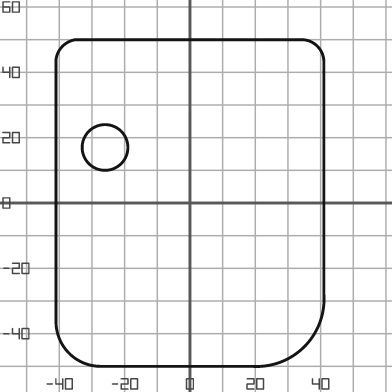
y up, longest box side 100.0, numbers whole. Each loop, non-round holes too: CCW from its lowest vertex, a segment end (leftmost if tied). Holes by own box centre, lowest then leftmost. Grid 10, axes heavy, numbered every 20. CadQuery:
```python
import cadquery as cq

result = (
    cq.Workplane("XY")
    .moveTo(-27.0, -50.0)
    .lineTo(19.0, -50.0)
    .threePointArc((35.0, -44.0), (41.0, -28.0))
    .lineTo(41.0, 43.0)
    .threePointArc((39.0, 48.0), (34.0, 50.0))
    .lineTo(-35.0, 50.0)
    .threePointArc((-39.0, 48.0), (-41.0, 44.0))
    .lineTo(-41.0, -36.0)
    .threePointArc((-37.0, -46.0), (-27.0, -50.0))
    .close()
    .moveTo(-26.0, 17.0)
    .circle(7.0)
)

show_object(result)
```